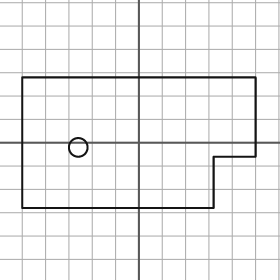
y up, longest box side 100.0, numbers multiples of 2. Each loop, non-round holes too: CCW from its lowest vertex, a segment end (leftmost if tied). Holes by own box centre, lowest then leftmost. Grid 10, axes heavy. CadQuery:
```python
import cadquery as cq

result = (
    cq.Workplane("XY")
    .moveTo(-50.0, -28.0)
    .lineTo(32.0, -28.0)
    .lineTo(32.0, -6.0)
    .lineTo(50.0, -6.0)
    .lineTo(50.0, 28.0)
    .lineTo(-50.0, 28.0)
    .close()
    .moveTo(-26.0, -2.0)
    .circle(4.0)
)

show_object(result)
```